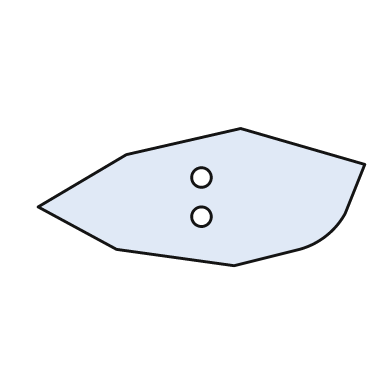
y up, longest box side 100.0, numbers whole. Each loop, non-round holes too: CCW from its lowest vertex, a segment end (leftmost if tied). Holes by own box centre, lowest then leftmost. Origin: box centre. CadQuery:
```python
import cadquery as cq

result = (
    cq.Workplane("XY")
    .moveTo(10.0, -21.0)
    .lineTo(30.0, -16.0)
    .threePointArc((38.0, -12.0), (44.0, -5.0))
    .lineTo(50.0, 10.0)
    .lineTo(12.0, 21.0)
    .lineTo(-23.0, 13.0)
    .lineTo(-50.0, -3.0)
    .lineTo(-26.0, -16.0)
    .close()
    .moveTo(0.0, -6.0)
    .circle(3.0)
    .moveTo(0.0, 6.0)
    .circle(3.0)
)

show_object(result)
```